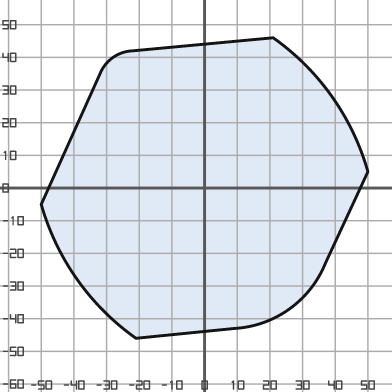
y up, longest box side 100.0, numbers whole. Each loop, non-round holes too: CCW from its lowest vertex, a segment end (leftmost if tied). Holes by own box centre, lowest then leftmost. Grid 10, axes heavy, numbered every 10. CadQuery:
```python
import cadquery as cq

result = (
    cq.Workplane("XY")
    .moveTo(-21.0, -46.0)
    .lineTo(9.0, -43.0)
    .threePointArc((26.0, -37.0), (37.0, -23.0))
    .lineTo(50.0, 5.0)
    .threePointArc((39.0, 28.0), (21.0, 46.0))
    .lineTo(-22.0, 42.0)
    .threePointArc((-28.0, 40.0), (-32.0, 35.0))
    .lineTo(-50.0, -5.0)
    .threePointArc((-39.0, -28.0), (-21.0, -46.0))
    .close()
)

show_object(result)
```